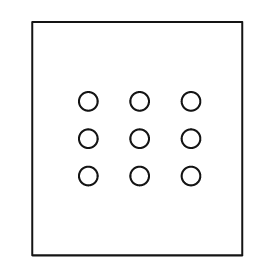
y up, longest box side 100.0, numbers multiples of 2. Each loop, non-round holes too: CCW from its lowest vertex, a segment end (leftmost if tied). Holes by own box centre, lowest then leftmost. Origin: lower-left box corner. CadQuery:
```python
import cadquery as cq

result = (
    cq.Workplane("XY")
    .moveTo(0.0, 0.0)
    .lineTo(90.0, 0.0)
    .lineTo(90.0, 100.0)
    .lineTo(0.0, 100.0)
    .close()
    .moveTo(24.0, 34.0)
    .circle(4.0)
    .moveTo(46.0, 34.0)
    .circle(4.0)
    .moveTo(68.0, 34.0)
    .circle(4.0)
    .moveTo(24.0, 50.0)
    .circle(4.0)
    .moveTo(46.0, 50.0)
    .circle(4.0)
    .moveTo(68.0, 50.0)
    .circle(4.0)
    .moveTo(24.0, 66.0)
    .circle(4.0)
    .moveTo(46.0, 66.0)
    .circle(4.0)
    .moveTo(68.0, 66.0)
    .circle(4.0)
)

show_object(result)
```